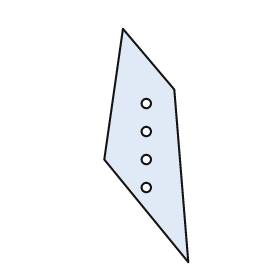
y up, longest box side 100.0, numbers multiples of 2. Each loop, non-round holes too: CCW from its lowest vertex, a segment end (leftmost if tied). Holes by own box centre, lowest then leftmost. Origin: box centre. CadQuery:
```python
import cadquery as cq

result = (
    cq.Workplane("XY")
    .moveTo(18.0, -50.0)
    .lineTo(12.0, 24.0)
    .lineTo(-10.0, 50.0)
    .lineTo(-18.0, -6.0)
    .close()
    .moveTo(0.0, -18.0)
    .circle(2.0)
    .moveTo(0.0, -6.0)
    .circle(2.0)
    .moveTo(0.0, 6.0)
    .circle(2.0)
    .moveTo(0.0, 18.0)
    .circle(2.0)
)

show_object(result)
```